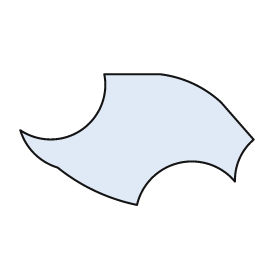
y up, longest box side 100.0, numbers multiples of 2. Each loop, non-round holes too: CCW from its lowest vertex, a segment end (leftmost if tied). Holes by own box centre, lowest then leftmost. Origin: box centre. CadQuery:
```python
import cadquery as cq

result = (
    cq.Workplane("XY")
    .moveTo(0.0, -28.0)
    .threePointArc((18.0, -10.0), (42.0, -18.0))
    .threePointArc((44.0, -8.0), (50.0, 0.0))
    .lineTo(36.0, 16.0)
    .threePointArc((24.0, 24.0), (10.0, 28.0))
    .lineTo(-14.0, 28.0)
    .threePointArc((-24.0, 4.0), (-50.0, 4.0))
    .threePointArc((-44.0, -6.0), (-34.0, -12.0))
    .threePointArc((-18.0, -22.0), (0.0, -28.0))
    .close()
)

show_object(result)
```